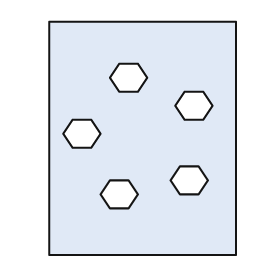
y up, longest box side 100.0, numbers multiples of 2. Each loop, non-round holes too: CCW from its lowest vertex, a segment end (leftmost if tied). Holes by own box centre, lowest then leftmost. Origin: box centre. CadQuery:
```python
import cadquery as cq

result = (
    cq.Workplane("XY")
    .moveTo(-40.0, -50.0)
    .lineTo(40.0, -50.0)
    .lineTo(40.0, 50.0)
    .lineTo(-40.0, 50.0)
    .close()
    .moveTo(-14.0, -30.0)
    .lineTo(-6.0, -30.0)
    .lineTo(-2.0, -24.0)
    .lineTo(-6.0, -18.0)
    .lineTo(-14.0, -18.0)
    .lineTo(-18.0, -24.0)
    .close()
    .moveTo(16.0, -24.0)
    .lineTo(24.0, -24.0)
    .lineTo(28.0, -18.0)
    .lineTo(24.0, -12.0)
    .lineTo(16.0, -12.0)
    .lineTo(12.0, -18.0)
    .close()
    .moveTo(-30.0, -4.0)
    .lineTo(-22.0, -4.0)
    .lineTo(-18.0, 2.0)
    .lineTo(-22.0, 8.0)
    .lineTo(-30.0, 8.0)
    .lineTo(-34.0, 2.0)
    .close()
    .moveTo(18.0, 8.0)
    .lineTo(26.0, 8.0)
    .lineTo(30.0, 14.0)
    .lineTo(26.0, 20.0)
    .lineTo(18.0, 20.0)
    .lineTo(14.0, 14.0)
    .close()
    .moveTo(-10.0, 20.0)
    .lineTo(-2.0, 20.0)
    .lineTo(2.0, 26.0)
    .lineTo(-2.0, 32.0)
    .lineTo(-10.0, 32.0)
    .lineTo(-14.0, 26.0)
    .close()
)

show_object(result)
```